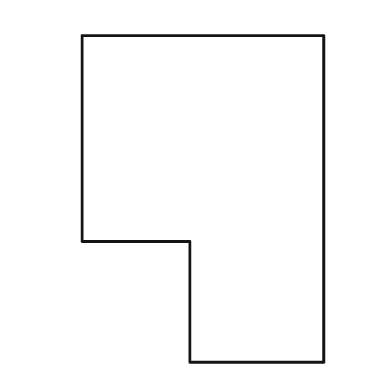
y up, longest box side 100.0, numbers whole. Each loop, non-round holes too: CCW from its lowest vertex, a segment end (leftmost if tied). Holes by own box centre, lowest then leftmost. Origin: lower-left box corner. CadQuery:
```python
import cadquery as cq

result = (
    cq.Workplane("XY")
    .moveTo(33.0, 0.0)
    .lineTo(74.0, 0.0)
    .lineTo(74.0, 100.0)
    .lineTo(0.0, 100.0)
    .lineTo(0.0, 37.0)
    .lineTo(33.0, 37.0)
    .close()
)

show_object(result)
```